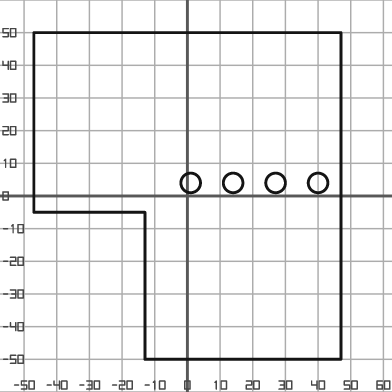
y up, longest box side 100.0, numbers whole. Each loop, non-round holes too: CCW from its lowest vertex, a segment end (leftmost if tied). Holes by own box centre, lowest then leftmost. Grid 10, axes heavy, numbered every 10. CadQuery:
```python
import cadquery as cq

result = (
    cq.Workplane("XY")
    .moveTo(-13.0, -50.0)
    .lineTo(47.0, -50.0)
    .lineTo(47.0, 50.0)
    .lineTo(-47.0, 50.0)
    .lineTo(-47.0, -5.0)
    .lineTo(-13.0, -5.0)
    .close()
    .moveTo(1.0, 4.0)
    .circle(3.0)
    .moveTo(14.0, 4.0)
    .circle(3.0)
    .moveTo(27.0, 4.0)
    .circle(3.0)
    .moveTo(40.0, 4.0)
    .circle(3.0)
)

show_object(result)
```